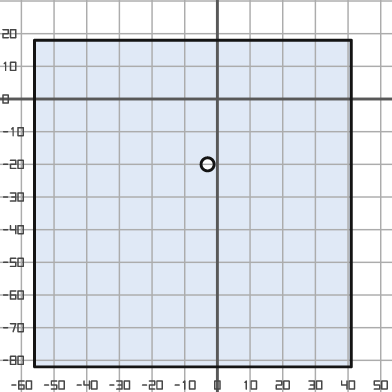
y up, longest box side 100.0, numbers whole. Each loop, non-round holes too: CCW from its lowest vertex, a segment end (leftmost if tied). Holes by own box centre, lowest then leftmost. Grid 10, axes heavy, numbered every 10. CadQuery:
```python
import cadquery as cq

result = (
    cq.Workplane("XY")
    .moveTo(-56.0, -82.0)
    .lineTo(41.0, -82.0)
    .lineTo(41.0, 18.0)
    .lineTo(-56.0, 18.0)
    .close()
    .moveTo(-3.0, -20.0)
    .circle(2.0)
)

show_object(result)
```